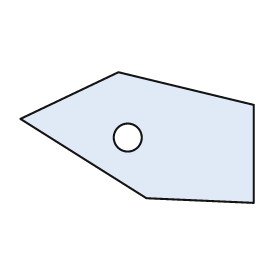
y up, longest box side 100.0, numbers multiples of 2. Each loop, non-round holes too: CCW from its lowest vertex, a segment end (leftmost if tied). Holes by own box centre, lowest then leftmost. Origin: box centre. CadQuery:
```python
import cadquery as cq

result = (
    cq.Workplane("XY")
    .moveTo(50.0, -28.0)
    .lineTo(50.0, 14.0)
    .lineTo(-8.0, 28.0)
    .lineTo(-50.0, 8.0)
    .lineTo(4.0, -26.0)
    .close()
    .moveTo(-4.0, 0.0)
    .circle(6.0)
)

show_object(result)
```